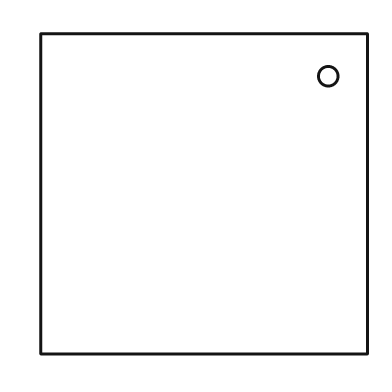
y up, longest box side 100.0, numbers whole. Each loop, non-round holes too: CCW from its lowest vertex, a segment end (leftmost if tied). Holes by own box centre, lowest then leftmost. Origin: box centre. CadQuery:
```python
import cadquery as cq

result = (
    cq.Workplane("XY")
    .moveTo(-50.0, -49.0)
    .lineTo(50.0, -49.0)
    .lineTo(50.0, 49.0)
    .lineTo(-50.0, 49.0)
    .close()
    .moveTo(38.0, 36.0)
    .circle(3.0)
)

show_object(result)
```